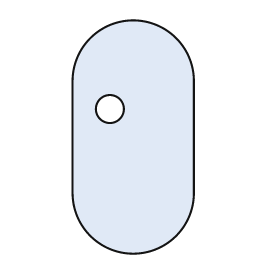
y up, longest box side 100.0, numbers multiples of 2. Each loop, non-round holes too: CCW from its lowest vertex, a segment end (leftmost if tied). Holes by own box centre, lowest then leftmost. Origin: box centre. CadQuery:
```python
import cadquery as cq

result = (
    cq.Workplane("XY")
    .moveTo(-26.0, -24.0)
    .threePointArc((0.0, -50.0), (26.0, -24.0))
    .lineTo(26.0, 24.0)
    .threePointArc((0.0, 50.0), (-26.0, 24.0))
    .close()
    .moveTo(-10.0, 12.0)
    .circle(6.0)
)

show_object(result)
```